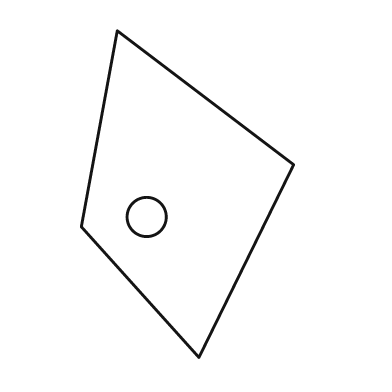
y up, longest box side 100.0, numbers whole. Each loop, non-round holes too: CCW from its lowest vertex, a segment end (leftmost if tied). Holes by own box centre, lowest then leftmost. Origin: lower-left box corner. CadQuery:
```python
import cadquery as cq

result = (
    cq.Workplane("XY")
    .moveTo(36.0, 0.0)
    .lineTo(65.0, 59.0)
    .lineTo(11.0, 100.0)
    .lineTo(0.0, 40.0)
    .close()
    .moveTo(20.0, 43.0)
    .circle(6.0)
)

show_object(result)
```